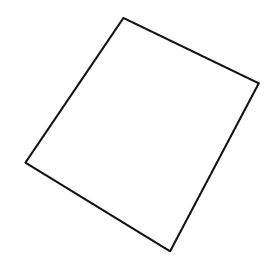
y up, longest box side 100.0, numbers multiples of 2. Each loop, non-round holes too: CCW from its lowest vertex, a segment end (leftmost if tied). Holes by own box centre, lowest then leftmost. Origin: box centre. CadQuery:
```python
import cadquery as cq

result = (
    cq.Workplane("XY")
    .moveTo(12.0, -50.0)
    .lineTo(50.0, 22.0)
    .lineTo(-8.0, 50.0)
    .lineTo(-50.0, -12.0)
    .close()
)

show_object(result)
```